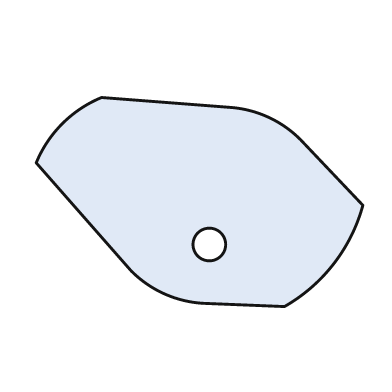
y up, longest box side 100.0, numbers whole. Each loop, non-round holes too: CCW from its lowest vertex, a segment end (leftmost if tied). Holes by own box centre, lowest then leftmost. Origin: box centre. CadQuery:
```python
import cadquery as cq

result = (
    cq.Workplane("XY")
    .moveTo(26.0, -32.0)
    .threePointArc((41.0, -19.0), (50.0, -1.0))
    .lineTo(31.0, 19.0)
    .threePointArc((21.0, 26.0), (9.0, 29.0))
    .lineTo(-30.0, 32.0)
    .threePointArc((-42.0, 24.0), (-50.0, 12.0))
    .lineTo(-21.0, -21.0)
    .threePointArc((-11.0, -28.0), (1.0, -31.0))
    .close()
    .moveTo(3.0, -13.0)
    .circle(5.0)
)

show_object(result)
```